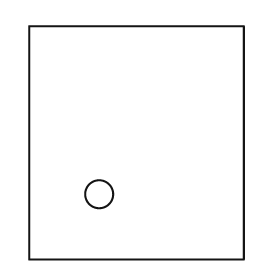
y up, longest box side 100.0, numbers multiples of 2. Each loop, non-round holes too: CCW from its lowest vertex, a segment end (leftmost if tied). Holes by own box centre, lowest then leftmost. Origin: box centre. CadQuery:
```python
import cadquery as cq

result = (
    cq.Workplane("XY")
    .moveTo(-46.0, -50.0)
    .lineTo(46.0, -50.0)
    .lineTo(46.0, 50.0)
    .lineTo(-46.0, 50.0)
    .close()
    .moveTo(-16.0, -22.0)
    .circle(6.0)
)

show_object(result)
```